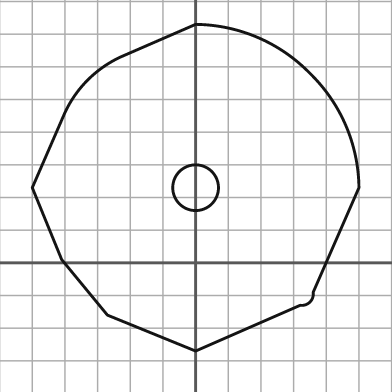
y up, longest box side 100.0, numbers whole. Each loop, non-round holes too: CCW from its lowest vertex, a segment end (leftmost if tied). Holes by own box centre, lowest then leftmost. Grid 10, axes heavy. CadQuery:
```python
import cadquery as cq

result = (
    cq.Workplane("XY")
    .moveTo(0.0, -27.0)
    .lineTo(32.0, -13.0)
    .threePointArc((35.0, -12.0), (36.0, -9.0))
    .lineTo(50.0, 23.0)
    .threePointArc((46.0, 42.0), (35.0, 58.0))
    .threePointArc((19.0, 69.0), (0.0, 73.0))
    .lineTo(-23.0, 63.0)
    .threePointArc((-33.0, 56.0), (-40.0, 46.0))
    .lineTo(-50.0, 23.0)
    .lineTo(-41.0, 1.0)
    .lineTo(-27.0, -16.0)
    .close()
    .moveTo(0.0, 23.0)
    .circle(7.0)
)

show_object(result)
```